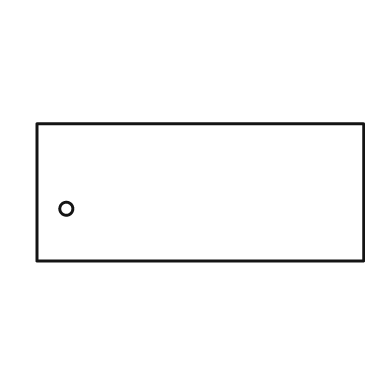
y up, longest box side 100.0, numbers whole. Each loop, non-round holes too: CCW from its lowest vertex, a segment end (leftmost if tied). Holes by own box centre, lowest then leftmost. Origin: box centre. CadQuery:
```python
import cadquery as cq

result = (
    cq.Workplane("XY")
    .moveTo(-50.0, -21.0)
    .lineTo(50.0, -21.0)
    .lineTo(50.0, 21.0)
    .lineTo(-50.0, 21.0)
    .close()
    .moveTo(-41.0, -5.0)
    .circle(2.0)
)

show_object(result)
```